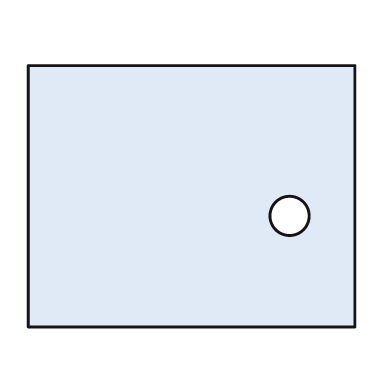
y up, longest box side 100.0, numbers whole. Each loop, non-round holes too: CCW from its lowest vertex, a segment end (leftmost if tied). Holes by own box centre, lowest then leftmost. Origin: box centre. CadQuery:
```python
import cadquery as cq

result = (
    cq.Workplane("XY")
    .moveTo(-50.0, -40.0)
    .lineTo(50.0, -40.0)
    .lineTo(50.0, 40.0)
    .lineTo(-50.0, 40.0)
    .close()
    .moveTo(30.0, -6.0)
    .circle(6.0)
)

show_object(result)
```